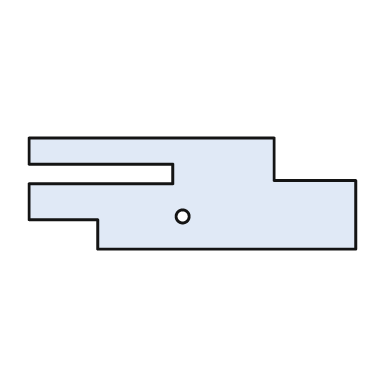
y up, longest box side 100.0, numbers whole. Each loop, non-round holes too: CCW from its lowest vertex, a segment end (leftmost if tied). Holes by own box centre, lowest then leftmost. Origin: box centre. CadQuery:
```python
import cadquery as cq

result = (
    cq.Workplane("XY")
    .moveTo(-29.0, -17.0)
    .lineTo(50.0, -17.0)
    .lineTo(50.0, 4.0)
    .lineTo(25.0, 4.0)
    .lineTo(25.0, 17.0)
    .lineTo(-50.0, 17.0)
    .lineTo(-50.0, 9.0)
    .lineTo(-6.0, 9.0)
    .lineTo(-6.0, 3.0)
    .lineTo(-50.0, 3.0)
    .lineTo(-50.0, -8.0)
    .lineTo(-29.0, -8.0)
    .close()
    .moveTo(-3.0, -7.0)
    .circle(2.0)
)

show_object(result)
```